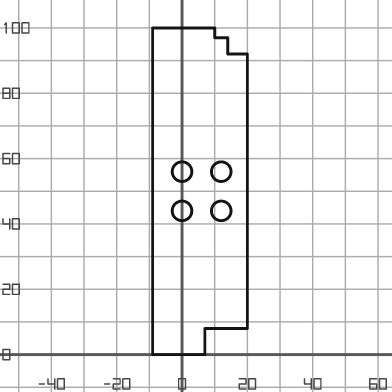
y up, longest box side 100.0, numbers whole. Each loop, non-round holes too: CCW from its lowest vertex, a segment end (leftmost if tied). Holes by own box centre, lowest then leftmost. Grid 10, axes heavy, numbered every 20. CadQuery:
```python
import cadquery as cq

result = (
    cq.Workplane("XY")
    .moveTo(-9.0, 0.0)
    .lineTo(7.0, 0.0)
    .lineTo(7.0, 8.0)
    .lineTo(20.0, 8.0)
    .lineTo(20.0, 92.0)
    .lineTo(14.0, 92.0)
    .lineTo(14.0, 97.0)
    .lineTo(10.0, 97.0)
    .lineTo(10.0, 100.0)
    .lineTo(-9.0, 100.0)
    .close()
    .moveTo(0.0, 44.0)
    .circle(3.0)
    .moveTo(12.0, 44.0)
    .circle(3.0)
    .moveTo(0.0, 56.0)
    .circle(3.0)
    .moveTo(12.0, 56.0)
    .circle(3.0)
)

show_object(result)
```